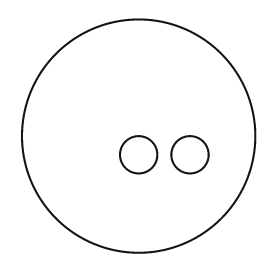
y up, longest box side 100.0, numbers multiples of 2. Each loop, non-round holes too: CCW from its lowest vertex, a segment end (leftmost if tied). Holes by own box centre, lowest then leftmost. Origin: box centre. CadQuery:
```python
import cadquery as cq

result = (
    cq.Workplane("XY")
    .moveTo(0.0, 0.0)
    .circle(50.0)
    .moveTo(0.0, -8.0)
    .circle(8.0)
    .moveTo(22.0, -8.0)
    .circle(8.0)
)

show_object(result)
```